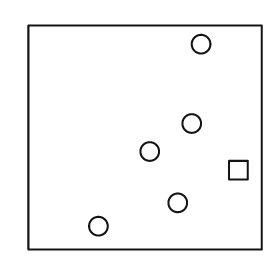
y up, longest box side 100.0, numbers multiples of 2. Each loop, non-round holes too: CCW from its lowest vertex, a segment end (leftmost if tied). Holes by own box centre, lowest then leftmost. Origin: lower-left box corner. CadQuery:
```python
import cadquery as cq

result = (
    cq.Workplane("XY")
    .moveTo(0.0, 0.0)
    .lineTo(100.0, 0.0)
    .lineTo(100.0, 96.0)
    .lineTo(0.0, 96.0)
    .close()
    .moveTo(30.0, 10.0)
    .circle(4.0)
    .moveTo(64.0, 20.0)
    .circle(4.0)
    .moveTo(86.0, 30.0)
    .lineTo(94.0, 30.0)
    .lineTo(94.0, 38.0)
    .lineTo(86.0, 38.0)
    .close()
    .moveTo(52.0, 42.0)
    .circle(4.0)
    .moveTo(70.0, 54.0)
    .circle(4.0)
    .moveTo(74.0, 88.0)
    .circle(4.0)
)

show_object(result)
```